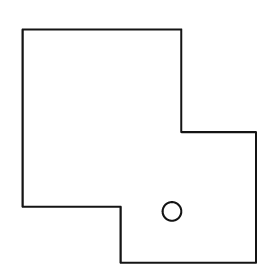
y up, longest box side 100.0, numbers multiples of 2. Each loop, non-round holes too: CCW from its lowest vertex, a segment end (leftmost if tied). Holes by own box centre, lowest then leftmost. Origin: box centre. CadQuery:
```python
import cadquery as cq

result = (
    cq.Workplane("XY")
    .moveTo(-8.0, -50.0)
    .lineTo(50.0, -50.0)
    .lineTo(50.0, 6.0)
    .lineTo(18.0, 6.0)
    .lineTo(18.0, 50.0)
    .lineTo(-50.0, 50.0)
    .lineTo(-50.0, -26.0)
    .lineTo(-8.0, -26.0)
    .close()
    .moveTo(14.0, -28.0)
    .circle(4.0)
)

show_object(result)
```